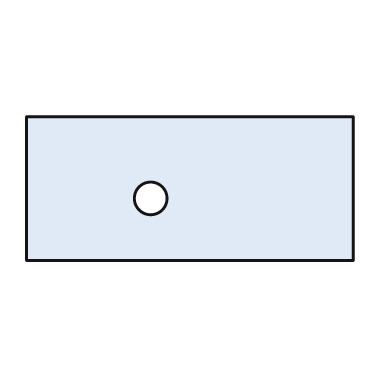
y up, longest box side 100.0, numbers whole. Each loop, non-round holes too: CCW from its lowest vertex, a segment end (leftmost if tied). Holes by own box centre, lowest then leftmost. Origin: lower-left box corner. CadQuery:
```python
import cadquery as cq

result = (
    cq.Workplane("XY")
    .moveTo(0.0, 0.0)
    .lineTo(100.0, 0.0)
    .lineTo(100.0, 44.0)
    .lineTo(0.0, 44.0)
    .close()
    .moveTo(38.0, 19.0)
    .circle(5.0)
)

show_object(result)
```